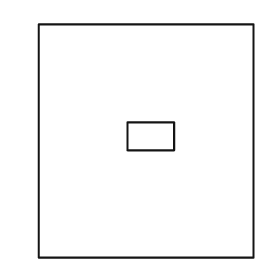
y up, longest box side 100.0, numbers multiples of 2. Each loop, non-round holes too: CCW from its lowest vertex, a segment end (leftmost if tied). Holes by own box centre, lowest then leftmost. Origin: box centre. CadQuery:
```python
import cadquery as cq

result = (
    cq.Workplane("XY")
    .moveTo(-46.0, -50.0)
    .lineTo(46.0, -50.0)
    .lineTo(46.0, 50.0)
    .lineTo(-46.0, 50.0)
    .close()
    .moveTo(-8.0, -4.0)
    .lineTo(12.0, -4.0)
    .lineTo(12.0, 8.0)
    .lineTo(-8.0, 8.0)
    .close()
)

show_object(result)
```